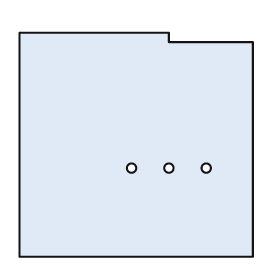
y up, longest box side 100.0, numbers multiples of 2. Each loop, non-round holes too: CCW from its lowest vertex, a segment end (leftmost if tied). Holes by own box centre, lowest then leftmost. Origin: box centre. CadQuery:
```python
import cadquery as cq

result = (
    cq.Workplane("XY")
    .moveTo(-50.0, -48.0)
    .lineTo(50.0, -48.0)
    .lineTo(50.0, 44.0)
    .lineTo(14.0, 44.0)
    .lineTo(14.0, 48.0)
    .lineTo(-50.0, 48.0)
    .close()
    .moveTo(-2.0, -10.0)
    .circle(2.0)
    .moveTo(14.0, -10.0)
    .circle(2.0)
    .moveTo(30.0, -10.0)
    .circle(2.0)
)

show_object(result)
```